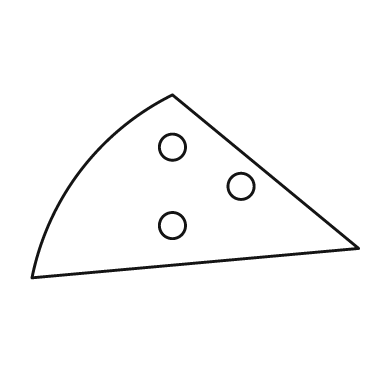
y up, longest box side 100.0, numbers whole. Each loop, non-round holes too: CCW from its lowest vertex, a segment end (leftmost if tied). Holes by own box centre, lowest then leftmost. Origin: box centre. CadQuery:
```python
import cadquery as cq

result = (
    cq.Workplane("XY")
    .moveTo(-50.0, -28.0)
    .lineTo(50.0, -19.0)
    .lineTo(-7.0, 28.0)
    .threePointArc((-35.0, 5.0), (-50.0, -28.0))
    .close()
    .moveTo(-7.0, -12.0)
    .circle(4.0)
    .moveTo(14.0, 0.0)
    .circle(4.0)
    .moveTo(-7.0, 12.0)
    .circle(4.0)
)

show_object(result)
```